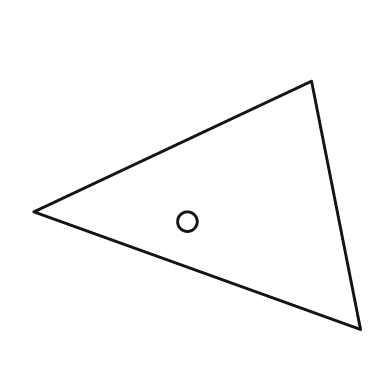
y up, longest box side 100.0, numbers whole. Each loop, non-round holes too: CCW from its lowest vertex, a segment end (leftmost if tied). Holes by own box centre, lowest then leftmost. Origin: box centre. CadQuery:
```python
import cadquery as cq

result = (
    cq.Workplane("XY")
    .moveTo(50.0, -38.0)
    .lineTo(35.0, 38.0)
    .lineTo(-50.0, -2.0)
    .close()
    .moveTo(-3.0, -5.0)
    .circle(3.0)
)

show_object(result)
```